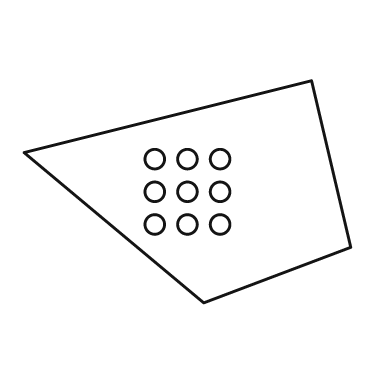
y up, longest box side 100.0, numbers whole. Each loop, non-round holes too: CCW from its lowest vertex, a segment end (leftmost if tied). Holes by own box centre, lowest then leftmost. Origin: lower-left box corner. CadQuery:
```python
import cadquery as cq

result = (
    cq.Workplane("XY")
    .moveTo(55.0, 0.0)
    .lineTo(100.0, 17.0)
    .lineTo(88.0, 68.0)
    .lineTo(0.0, 46.0)
    .close()
    .moveTo(40.0, 24.0)
    .circle(3.0)
    .moveTo(50.0, 24.0)
    .circle(3.0)
    .moveTo(60.0, 24.0)
    .circle(3.0)
    .moveTo(40.0, 34.0)
    .circle(3.0)
    .moveTo(50.0, 34.0)
    .circle(3.0)
    .moveTo(60.0, 34.0)
    .circle(3.0)
    .moveTo(40.0, 44.0)
    .circle(3.0)
    .moveTo(50.0, 44.0)
    .circle(3.0)
    .moveTo(60.0, 44.0)
    .circle(3.0)
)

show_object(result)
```